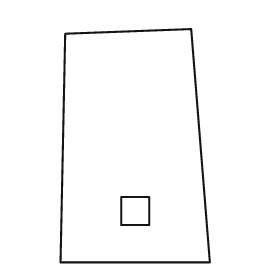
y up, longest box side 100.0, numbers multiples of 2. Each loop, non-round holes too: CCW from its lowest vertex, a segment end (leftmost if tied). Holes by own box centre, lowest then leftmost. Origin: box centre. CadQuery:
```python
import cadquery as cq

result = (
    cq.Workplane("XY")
    .moveTo(-32.0, -50.0)
    .lineTo(32.0, -50.0)
    .lineTo(24.0, 50.0)
    .lineTo(-30.0, 48.0)
    .close()
    .moveTo(-6.0, -34.0)
    .lineTo(6.0, -34.0)
    .lineTo(6.0, -22.0)
    .lineTo(-6.0, -22.0)
    .close()
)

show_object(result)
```